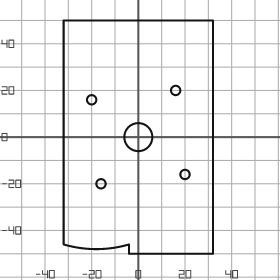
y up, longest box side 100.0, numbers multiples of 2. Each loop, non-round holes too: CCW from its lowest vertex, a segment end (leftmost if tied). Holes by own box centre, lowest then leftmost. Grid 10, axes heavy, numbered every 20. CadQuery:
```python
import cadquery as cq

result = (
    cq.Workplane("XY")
    .moveTo(-4.0, -50.0)
    .lineTo(32.0, -50.0)
    .lineTo(32.0, 50.0)
    .lineTo(-32.0, 50.0)
    .lineTo(-32.0, -46.0)
    .threePointArc((-18.0, -48.0), (-4.0, -46.0))
    .close()
    .moveTo(-16.0, -20.0)
    .circle(2.0)
    .moveTo(20.0, -16.0)
    .circle(2.0)
    .moveTo(0.0, 0.0)
    .circle(6.0)
    .moveTo(-20.0, 16.0)
    .circle(2.0)
    .moveTo(16.0, 20.0)
    .circle(2.0)
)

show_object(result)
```